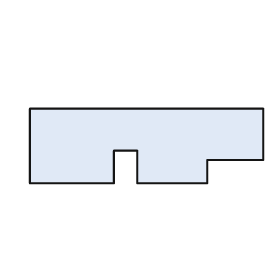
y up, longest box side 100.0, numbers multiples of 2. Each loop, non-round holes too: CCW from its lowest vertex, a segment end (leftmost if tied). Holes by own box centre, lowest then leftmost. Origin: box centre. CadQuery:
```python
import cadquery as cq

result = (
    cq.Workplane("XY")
    .moveTo(-50.0, -16.0)
    .lineTo(-14.0, -16.0)
    .lineTo(-14.0, -2.0)
    .lineTo(-4.0, -2.0)
    .lineTo(-4.0, -16.0)
    .lineTo(26.0, -16.0)
    .lineTo(26.0, -6.0)
    .lineTo(50.0, -6.0)
    .lineTo(50.0, 16.0)
    .lineTo(-50.0, 16.0)
    .close()
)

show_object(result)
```